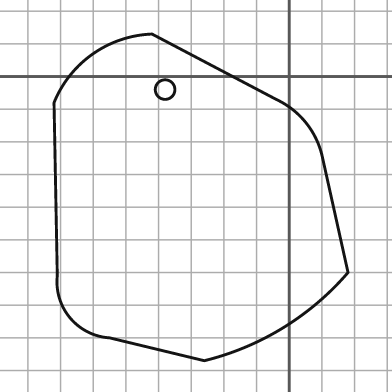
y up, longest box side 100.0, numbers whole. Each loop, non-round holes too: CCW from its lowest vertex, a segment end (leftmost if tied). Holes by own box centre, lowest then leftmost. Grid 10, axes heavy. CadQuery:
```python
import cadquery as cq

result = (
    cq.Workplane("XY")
    .moveTo(-26.0, -87.0)
    .threePointArc((-2.0, -77.0), (18.0, -60.0))
    .lineTo(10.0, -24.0)
    .threePointArc((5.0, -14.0), (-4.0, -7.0))
    .lineTo(-42.0, 13.0)
    .threePointArc((-60.0, 7.0), (-72.0, -8.0))
    .lineTo(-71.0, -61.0)
    .threePointArc((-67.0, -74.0), (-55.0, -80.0))
    .close()
    .moveTo(-38.0, -4.0)
    .circle(3.0)
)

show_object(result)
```